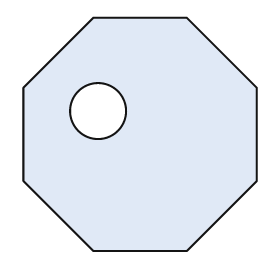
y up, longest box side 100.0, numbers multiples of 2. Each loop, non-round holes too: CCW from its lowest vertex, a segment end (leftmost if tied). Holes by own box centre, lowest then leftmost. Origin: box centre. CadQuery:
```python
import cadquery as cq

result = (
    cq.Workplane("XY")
    .moveTo(-20.0, -50.0)
    .lineTo(20.0, -50.0)
    .lineTo(50.0, -20.0)
    .lineTo(50.0, 20.0)
    .lineTo(20.0, 50.0)
    .lineTo(-20.0, 50.0)
    .lineTo(-50.0, 20.0)
    .lineTo(-50.0, -20.0)
    .close()
    .moveTo(-18.0, 10.0)
    .circle(12.0)
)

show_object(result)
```